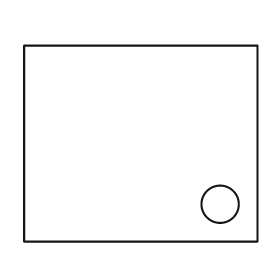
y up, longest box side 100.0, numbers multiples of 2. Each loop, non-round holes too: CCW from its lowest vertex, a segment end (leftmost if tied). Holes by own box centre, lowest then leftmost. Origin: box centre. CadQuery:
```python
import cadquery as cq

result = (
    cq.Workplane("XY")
    .moveTo(-50.0, -42.0)
    .lineTo(50.0, -42.0)
    .lineTo(50.0, 42.0)
    .lineTo(-50.0, 42.0)
    .close()
    .moveTo(34.0, -26.0)
    .circle(8.0)
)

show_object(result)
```